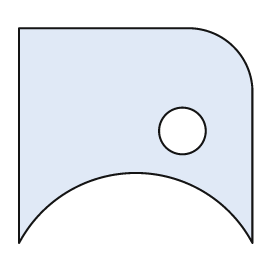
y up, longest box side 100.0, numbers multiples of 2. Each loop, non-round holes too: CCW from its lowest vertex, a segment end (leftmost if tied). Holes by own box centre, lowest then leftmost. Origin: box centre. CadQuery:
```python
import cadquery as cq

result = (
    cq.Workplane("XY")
    .moveTo(-50.0, -46.0)
    .threePointArc((0.0, -16.0), (50.0, -46.0))
    .lineTo(50.0, 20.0)
    .threePointArc((42.0, 38.0), (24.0, 46.0))
    .lineTo(-50.0, 46.0)
    .close()
    .moveTo(20.0, 2.0)
    .circle(10.0)
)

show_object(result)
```